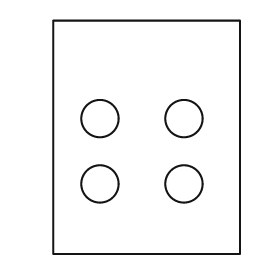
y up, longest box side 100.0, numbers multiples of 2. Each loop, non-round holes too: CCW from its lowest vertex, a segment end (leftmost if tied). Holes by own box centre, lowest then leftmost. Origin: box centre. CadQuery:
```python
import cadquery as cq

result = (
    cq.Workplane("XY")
    .moveTo(-40.0, -50.0)
    .lineTo(40.0, -50.0)
    .lineTo(40.0, 50.0)
    .lineTo(-40.0, 50.0)
    .close()
    .moveTo(-20.0, -20.0)
    .circle(8.0)
    .moveTo(16.0, -20.0)
    .circle(8.0)
    .moveTo(-20.0, 8.0)
    .circle(8.0)
    .moveTo(16.0, 8.0)
    .circle(8.0)
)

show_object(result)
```